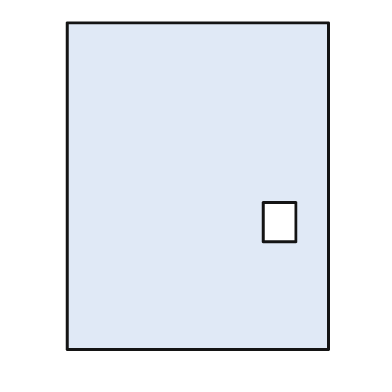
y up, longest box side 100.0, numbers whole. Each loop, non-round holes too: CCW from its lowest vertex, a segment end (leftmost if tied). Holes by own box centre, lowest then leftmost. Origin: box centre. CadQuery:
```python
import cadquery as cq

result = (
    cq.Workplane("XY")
    .moveTo(-40.0, -50.0)
    .lineTo(40.0, -50.0)
    .lineTo(40.0, 50.0)
    .lineTo(-40.0, 50.0)
    .close()
    .moveTo(20.0, -17.0)
    .lineTo(30.0, -17.0)
    .lineTo(30.0, -5.0)
    .lineTo(20.0, -5.0)
    .close()
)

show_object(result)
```